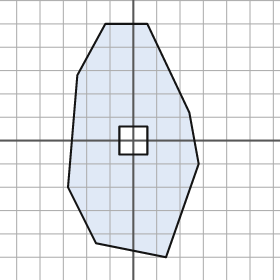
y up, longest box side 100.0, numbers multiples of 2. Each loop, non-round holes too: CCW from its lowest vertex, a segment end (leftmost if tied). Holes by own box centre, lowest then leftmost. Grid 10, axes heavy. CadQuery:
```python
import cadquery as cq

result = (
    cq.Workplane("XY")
    .moveTo(14.0, -50.0)
    .lineTo(28.0, -10.0)
    .lineTo(24.0, 12.0)
    .lineTo(6.0, 50.0)
    .lineTo(-12.0, 50.0)
    .lineTo(-24.0, 28.0)
    .lineTo(-28.0, -20.0)
    .lineTo(-16.0, -44.0)
    .close()
    .moveTo(-6.0, -6.0)
    .lineTo(6.0, -6.0)
    .lineTo(6.0, 6.0)
    .lineTo(-6.0, 6.0)
    .close()
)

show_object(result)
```